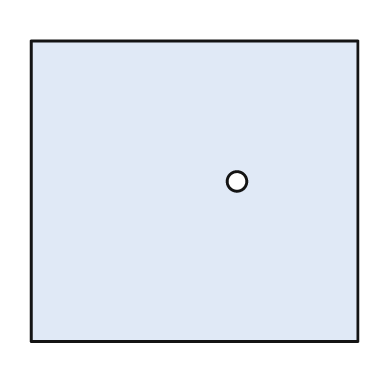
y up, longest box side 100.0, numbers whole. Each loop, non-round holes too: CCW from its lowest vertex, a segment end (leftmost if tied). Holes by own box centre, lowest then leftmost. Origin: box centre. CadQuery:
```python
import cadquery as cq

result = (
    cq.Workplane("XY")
    .moveTo(-50.0, -46.0)
    .lineTo(50.0, -46.0)
    .lineTo(50.0, 46.0)
    .lineTo(-50.0, 46.0)
    .close()
    .moveTo(13.0, 3.0)
    .circle(3.0)
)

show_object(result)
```